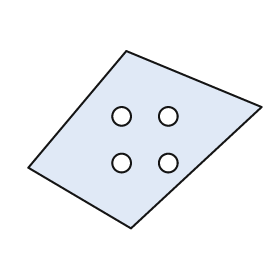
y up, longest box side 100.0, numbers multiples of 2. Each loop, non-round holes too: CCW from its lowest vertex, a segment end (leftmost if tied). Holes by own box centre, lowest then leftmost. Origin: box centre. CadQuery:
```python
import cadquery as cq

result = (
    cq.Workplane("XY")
    .moveTo(-6.0, -38.0)
    .lineTo(50.0, 14.0)
    .lineTo(-8.0, 38.0)
    .lineTo(-50.0, -12.0)
    .close()
    .moveTo(-10.0, -10.0)
    .circle(4.0)
    .moveTo(10.0, -10.0)
    .circle(4.0)
    .moveTo(-10.0, 10.0)
    .circle(4.0)
    .moveTo(10.0, 10.0)
    .circle(4.0)
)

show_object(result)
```